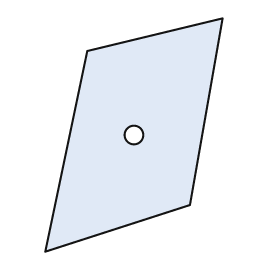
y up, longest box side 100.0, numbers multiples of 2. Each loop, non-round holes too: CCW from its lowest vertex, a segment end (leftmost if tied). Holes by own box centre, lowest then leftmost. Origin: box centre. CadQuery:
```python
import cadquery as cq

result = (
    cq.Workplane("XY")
    .moveTo(-38.0, -50.0)
    .lineTo(24.0, -30.0)
    .lineTo(38.0, 50.0)
    .lineTo(-20.0, 36.0)
    .close()
    .moveTo(0.0, 0.0)
    .circle(4.0)
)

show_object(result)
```